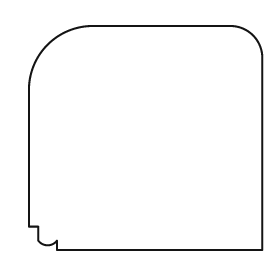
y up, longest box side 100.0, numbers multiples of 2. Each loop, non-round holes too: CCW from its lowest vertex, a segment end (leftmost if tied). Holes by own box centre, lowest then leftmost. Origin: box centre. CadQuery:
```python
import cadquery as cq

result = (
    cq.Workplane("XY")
    .moveTo(-38.0, -48.0)
    .lineTo(50.0, -48.0)
    .lineTo(50.0, 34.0)
    .threePointArc((46.0, 44.0), (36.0, 48.0))
    .lineTo(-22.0, 48.0)
    .threePointArc((-42.0, 40.0), (-50.0, 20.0))
    .lineTo(-50.0, -38.0)
    .lineTo(-46.0, -38.0)
    .lineTo(-46.0, -44.0)
    .threePointArc((-42.0, -46.0), (-38.0, -44.0))
    .close()
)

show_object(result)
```